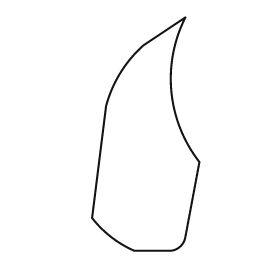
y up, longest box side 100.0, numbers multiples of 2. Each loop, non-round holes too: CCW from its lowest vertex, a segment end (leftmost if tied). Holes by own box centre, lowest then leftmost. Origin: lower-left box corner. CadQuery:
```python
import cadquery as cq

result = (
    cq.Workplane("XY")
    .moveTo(18.0, 0.0)
    .lineTo(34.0, 0.0)
    .threePointArc((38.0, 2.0), (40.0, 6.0))
    .lineTo(46.0, 38.0)
    .threePointArc((34.0, 68.0), (40.0, 100.0))
    .lineTo(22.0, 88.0)
    .threePointArc((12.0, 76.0), (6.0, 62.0))
    .lineTo(0.0, 14.0)
    .threePointArc((8.0, 6.0), (18.0, 0.0))
    .close()
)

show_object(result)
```